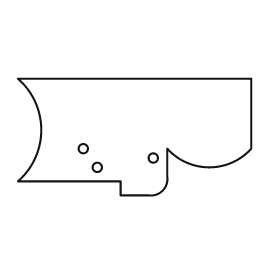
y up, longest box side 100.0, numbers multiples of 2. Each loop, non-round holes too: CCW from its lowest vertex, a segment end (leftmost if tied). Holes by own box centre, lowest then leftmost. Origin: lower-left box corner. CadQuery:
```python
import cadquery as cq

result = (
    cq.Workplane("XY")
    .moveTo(44.0, 0.0)
    .lineTo(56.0, 0.0)
    .threePointArc((62.0, 2.0), (64.0, 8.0))
    .lineTo(64.0, 20.0)
    .threePointArc((82.0, 12.0), (100.0, 20.0))
    .lineTo(100.0, 50.0)
    .lineTo(0.0, 50.0)
    .threePointArc((10.0, 28.0), (0.0, 6.0))
    .lineTo(44.0, 6.0)
    .close()
    .moveTo(34.0, 12.0)
    .circle(2.0)
    .moveTo(58.0, 16.0)
    .circle(2.0)
    .moveTo(28.0, 20.0)
    .circle(2.0)
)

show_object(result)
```